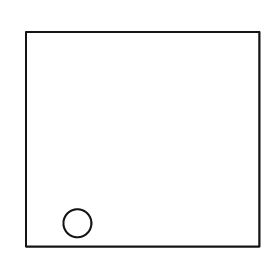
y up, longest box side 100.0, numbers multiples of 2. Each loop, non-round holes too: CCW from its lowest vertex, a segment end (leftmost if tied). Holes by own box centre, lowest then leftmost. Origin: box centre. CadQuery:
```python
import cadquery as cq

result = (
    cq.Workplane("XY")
    .moveTo(-50.0, -46.0)
    .lineTo(50.0, -46.0)
    .lineTo(50.0, 46.0)
    .lineTo(-50.0, 46.0)
    .close()
    .moveTo(-28.0, -36.0)
    .circle(6.0)
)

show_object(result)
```